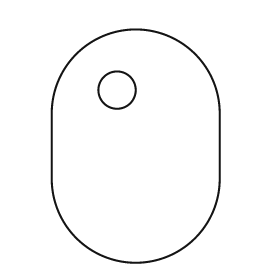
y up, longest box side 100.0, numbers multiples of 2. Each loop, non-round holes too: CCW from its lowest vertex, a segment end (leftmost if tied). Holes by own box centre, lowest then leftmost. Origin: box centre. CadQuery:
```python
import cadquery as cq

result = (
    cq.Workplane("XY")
    .moveTo(-36.0, -14.0)
    .threePointArc((0.0, -50.0), (36.0, -14.0))
    .lineTo(36.0, 14.0)
    .threePointArc((0.0, 50.0), (-36.0, 14.0))
    .close()
    .moveTo(-8.0, 24.0)
    .circle(8.0)
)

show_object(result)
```